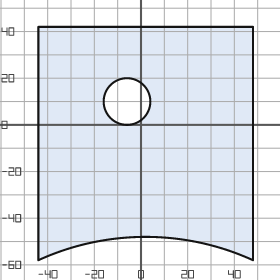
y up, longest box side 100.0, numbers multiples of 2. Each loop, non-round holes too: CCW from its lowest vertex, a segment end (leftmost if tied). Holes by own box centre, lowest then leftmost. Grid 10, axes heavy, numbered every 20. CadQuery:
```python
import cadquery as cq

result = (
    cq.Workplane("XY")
    .moveTo(-44.0, -58.0)
    .threePointArc((2.0, -48.0), (48.0, -58.0))
    .lineTo(48.0, 42.0)
    .lineTo(-44.0, 42.0)
    .close()
    .moveTo(-6.0, 10.0)
    .circle(10.0)
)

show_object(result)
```